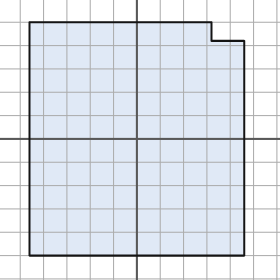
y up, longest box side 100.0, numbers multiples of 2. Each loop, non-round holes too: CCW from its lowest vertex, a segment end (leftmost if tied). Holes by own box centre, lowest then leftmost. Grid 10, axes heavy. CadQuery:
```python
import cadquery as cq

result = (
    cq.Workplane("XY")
    .moveTo(-46.0, -50.0)
    .lineTo(46.0, -50.0)
    .lineTo(46.0, 42.0)
    .lineTo(32.0, 42.0)
    .lineTo(32.0, 50.0)
    .lineTo(-46.0, 50.0)
    .close()
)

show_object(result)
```